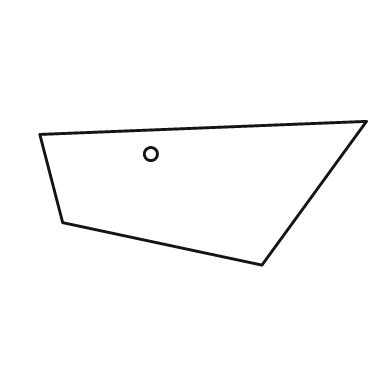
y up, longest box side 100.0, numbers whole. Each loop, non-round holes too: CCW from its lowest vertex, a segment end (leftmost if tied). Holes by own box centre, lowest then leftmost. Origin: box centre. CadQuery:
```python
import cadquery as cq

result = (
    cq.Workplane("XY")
    .moveTo(18.0, -22.0)
    .lineTo(50.0, 22.0)
    .lineTo(-50.0, 18.0)
    .lineTo(-43.0, -9.0)
    .close()
    .moveTo(-16.0, 12.0)
    .circle(2.0)
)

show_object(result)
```